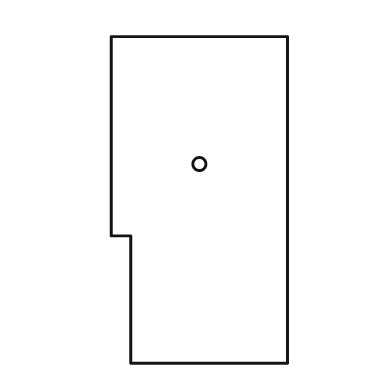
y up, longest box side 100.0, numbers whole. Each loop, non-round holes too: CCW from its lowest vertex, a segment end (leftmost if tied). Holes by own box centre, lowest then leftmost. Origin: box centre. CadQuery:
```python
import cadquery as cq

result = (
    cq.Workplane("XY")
    .moveTo(-21.0, -50.0)
    .lineTo(27.0, -50.0)
    .lineTo(27.0, 50.0)
    .lineTo(-27.0, 50.0)
    .lineTo(-27.0, -11.0)
    .lineTo(-21.0, -11.0)
    .close()
    .moveTo(0.0, 11.0)
    .circle(2.0)
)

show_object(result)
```